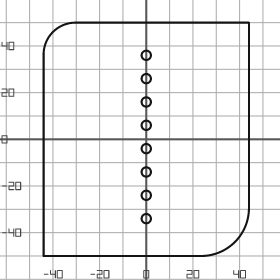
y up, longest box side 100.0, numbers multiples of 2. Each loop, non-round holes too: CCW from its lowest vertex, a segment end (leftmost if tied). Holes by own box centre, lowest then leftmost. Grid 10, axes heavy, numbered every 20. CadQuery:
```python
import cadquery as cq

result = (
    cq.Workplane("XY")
    .moveTo(-44.0, -50.0)
    .lineTo(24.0, -50.0)
    .threePointArc((38.0, -44.0), (44.0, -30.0))
    .lineTo(44.0, 50.0)
    .lineTo(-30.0, 50.0)
    .threePointArc((-40.0, 46.0), (-44.0, 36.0))
    .close()
    .moveTo(0.0, -34.0)
    .circle(2.0)
    .moveTo(0.0, -24.0)
    .circle(2.0)
    .moveTo(0.0, -14.0)
    .circle(2.0)
    .moveTo(0.0, -4.0)
    .circle(2.0)
    .moveTo(0.0, 6.0)
    .circle(2.0)
    .moveTo(0.0, 16.0)
    .circle(2.0)
    .moveTo(0.0, 26.0)
    .circle(2.0)
    .moveTo(0.0, 36.0)
    .circle(2.0)
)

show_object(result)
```